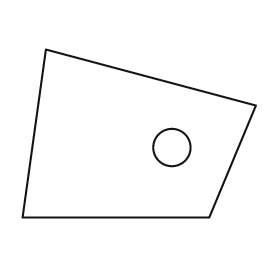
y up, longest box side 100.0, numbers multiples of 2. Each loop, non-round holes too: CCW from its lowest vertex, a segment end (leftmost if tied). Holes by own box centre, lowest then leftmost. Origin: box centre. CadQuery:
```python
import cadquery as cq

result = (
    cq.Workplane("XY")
    .moveTo(-50.0, -36.0)
    .lineTo(30.0, -36.0)
    .lineTo(50.0, 12.0)
    .lineTo(-40.0, 36.0)
    .close()
    .moveTo(14.0, -6.0)
    .circle(8.0)
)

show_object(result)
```